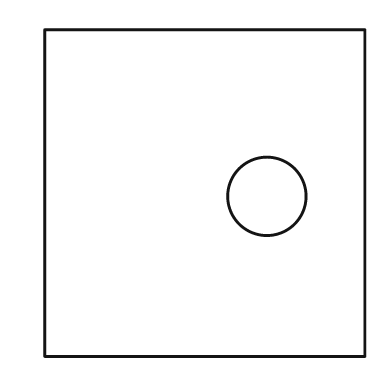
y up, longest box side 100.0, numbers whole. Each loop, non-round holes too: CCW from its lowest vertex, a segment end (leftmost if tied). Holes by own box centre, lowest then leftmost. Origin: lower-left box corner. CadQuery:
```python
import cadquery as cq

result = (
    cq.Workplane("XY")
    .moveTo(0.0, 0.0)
    .lineTo(98.0, 0.0)
    .lineTo(98.0, 100.0)
    .lineTo(0.0, 100.0)
    .close()
    .moveTo(68.0, 49.0)
    .circle(12.0)
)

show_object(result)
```